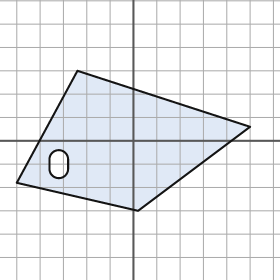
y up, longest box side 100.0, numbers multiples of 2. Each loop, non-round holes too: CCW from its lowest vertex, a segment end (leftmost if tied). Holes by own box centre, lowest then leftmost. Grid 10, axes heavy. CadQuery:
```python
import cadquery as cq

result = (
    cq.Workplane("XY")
    .moveTo(2.0, -30.0)
    .lineTo(50.0, 6.0)
    .lineTo(-24.0, 30.0)
    .lineTo(-50.0, -18.0)
    .close()
    .moveTo(-36.0, -12.0)
    .threePointArc((-32.0, -16.0), (-28.0, -12.0))
    .lineTo(-28.0, -8.0)
    .threePointArc((-32.0, -4.0), (-36.0, -8.0))
    .close()
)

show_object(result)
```